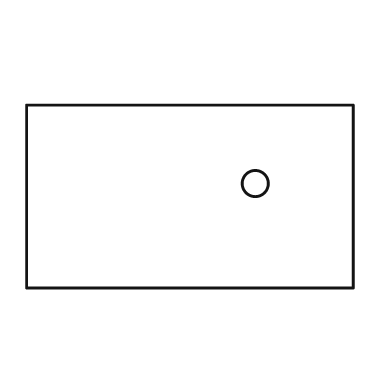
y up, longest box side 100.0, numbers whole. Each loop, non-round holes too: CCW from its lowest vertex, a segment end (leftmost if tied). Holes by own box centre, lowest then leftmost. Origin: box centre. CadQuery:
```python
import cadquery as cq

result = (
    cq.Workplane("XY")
    .moveTo(-50.0, -28.0)
    .lineTo(50.0, -28.0)
    .lineTo(50.0, 28.0)
    .lineTo(-50.0, 28.0)
    .close()
    .moveTo(20.0, 4.0)
    .circle(4.0)
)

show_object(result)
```